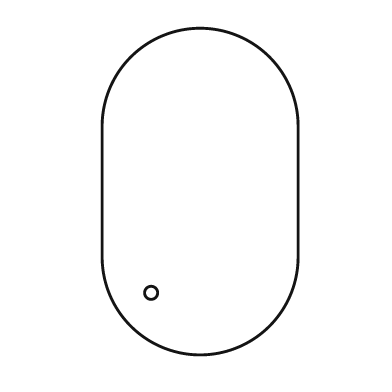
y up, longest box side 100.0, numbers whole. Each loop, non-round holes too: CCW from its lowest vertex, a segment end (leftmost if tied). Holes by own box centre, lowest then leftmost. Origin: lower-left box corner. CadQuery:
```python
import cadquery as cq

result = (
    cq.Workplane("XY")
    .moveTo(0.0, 30.0)
    .threePointArc((30.0, 0.0), (60.0, 30.0))
    .lineTo(60.0, 70.0)
    .threePointArc((30.0, 100.0), (0.0, 70.0))
    .close()
    .moveTo(15.0, 19.0)
    .circle(2.0)
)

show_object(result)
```